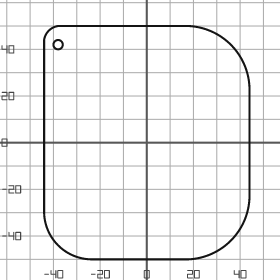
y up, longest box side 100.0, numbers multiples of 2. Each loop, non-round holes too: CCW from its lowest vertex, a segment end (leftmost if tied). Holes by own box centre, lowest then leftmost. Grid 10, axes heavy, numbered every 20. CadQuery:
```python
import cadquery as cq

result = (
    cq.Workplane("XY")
    .moveTo(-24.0, -50.0)
    .lineTo(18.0, -50.0)
    .threePointArc((36.0, -42.0), (44.0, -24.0))
    .lineTo(44.0, 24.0)
    .threePointArc((36.0, 42.0), (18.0, 50.0))
    .lineTo(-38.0, 50.0)
    .threePointArc((-42.0, 48.0), (-44.0, 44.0))
    .lineTo(-44.0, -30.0)
    .threePointArc((-38.0, -44.0), (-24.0, -50.0))
    .close()
    .moveTo(-38.0, 42.0)
    .circle(2.0)
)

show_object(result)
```